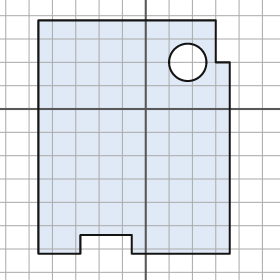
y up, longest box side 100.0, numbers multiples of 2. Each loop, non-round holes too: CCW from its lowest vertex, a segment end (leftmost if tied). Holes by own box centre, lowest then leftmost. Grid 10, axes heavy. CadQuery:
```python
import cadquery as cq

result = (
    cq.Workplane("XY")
    .moveTo(-46.0, -62.0)
    .lineTo(-28.0, -62.0)
    .lineTo(-28.0, -54.0)
    .lineTo(-6.0, -54.0)
    .lineTo(-6.0, -62.0)
    .lineTo(36.0, -62.0)
    .lineTo(36.0, 20.0)
    .lineTo(30.0, 20.0)
    .lineTo(30.0, 38.0)
    .lineTo(-46.0, 38.0)
    .close()
    .moveTo(18.0, 20.0)
    .circle(8.0)
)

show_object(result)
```